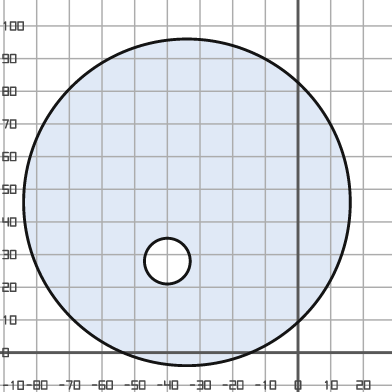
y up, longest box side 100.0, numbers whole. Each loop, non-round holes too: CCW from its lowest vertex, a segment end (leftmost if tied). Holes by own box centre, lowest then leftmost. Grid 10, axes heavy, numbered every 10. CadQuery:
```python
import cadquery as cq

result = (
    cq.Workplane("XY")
    .moveTo(-34.0, 46.0)
    .circle(50.0)
    .moveTo(-40.0, 28.0)
    .circle(7.0)
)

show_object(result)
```